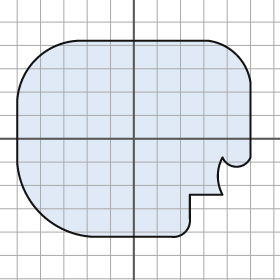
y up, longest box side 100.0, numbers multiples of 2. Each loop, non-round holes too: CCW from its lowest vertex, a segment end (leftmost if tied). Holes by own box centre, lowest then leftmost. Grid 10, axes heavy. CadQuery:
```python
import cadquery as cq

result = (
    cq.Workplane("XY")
    .moveTo(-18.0, -42.0)
    .lineTo(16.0, -42.0)
    .threePointArc((22.0, -40.0), (24.0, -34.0))
    .lineTo(24.0, -24.0)
    .lineTo(38.0, -24.0)
    .threePointArc((36.0, -16.0), (38.0, -8.0))
    .threePointArc((44.0, -12.0), (50.0, -8.0))
    .lineTo(50.0, 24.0)
    .threePointArc((44.0, 36.0), (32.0, 42.0))
    .lineTo(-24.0, 42.0)
    .threePointArc((-42.0, 34.0), (-50.0, 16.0))
    .lineTo(-50.0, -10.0)
    .threePointArc((-40.0, -32.0), (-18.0, -42.0))
    .close()
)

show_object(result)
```